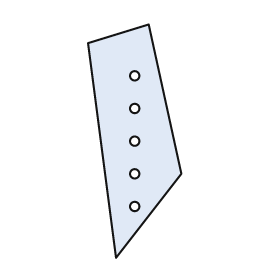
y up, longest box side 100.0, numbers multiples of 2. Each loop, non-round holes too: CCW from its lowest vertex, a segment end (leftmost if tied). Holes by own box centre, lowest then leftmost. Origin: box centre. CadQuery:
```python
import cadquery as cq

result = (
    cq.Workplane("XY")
    .moveTo(-8.0, -50.0)
    .lineTo(20.0, -14.0)
    .lineTo(6.0, 50.0)
    .lineTo(-20.0, 42.0)
    .close()
    .moveTo(0.0, -28.0)
    .circle(2.0)
    .moveTo(0.0, -14.0)
    .circle(2.0)
    .moveTo(0.0, 0.0)
    .circle(2.0)
    .moveTo(0.0, 14.0)
    .circle(2.0)
    .moveTo(0.0, 28.0)
    .circle(2.0)
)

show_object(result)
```